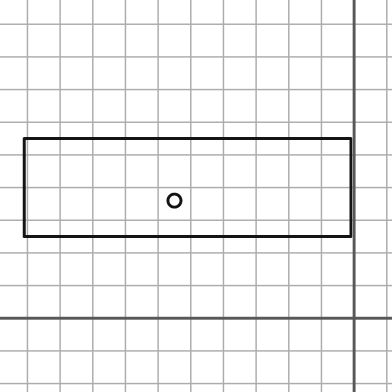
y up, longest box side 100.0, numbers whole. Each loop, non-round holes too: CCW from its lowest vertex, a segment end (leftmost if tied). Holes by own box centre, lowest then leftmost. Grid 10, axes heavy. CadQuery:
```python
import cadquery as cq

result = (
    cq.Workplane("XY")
    .moveTo(-101.0, 25.0)
    .lineTo(-1.0, 25.0)
    .lineTo(-1.0, 55.0)
    .lineTo(-101.0, 55.0)
    .close()
    .moveTo(-55.0, 36.0)
    .circle(2.0)
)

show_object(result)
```